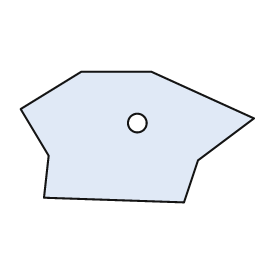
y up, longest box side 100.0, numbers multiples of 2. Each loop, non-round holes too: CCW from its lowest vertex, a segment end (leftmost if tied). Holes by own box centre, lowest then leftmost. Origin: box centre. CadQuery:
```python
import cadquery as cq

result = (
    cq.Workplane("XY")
    .moveTo(20.0, -28.0)
    .lineTo(26.0, -10.0)
    .lineTo(50.0, 8.0)
    .lineTo(6.0, 28.0)
    .lineTo(-24.0, 28.0)
    .lineTo(-50.0, 12.0)
    .lineTo(-38.0, -8.0)
    .lineTo(-40.0, -26.0)
    .close()
    .moveTo(0.0, 6.0)
    .circle(4.0)
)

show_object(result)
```